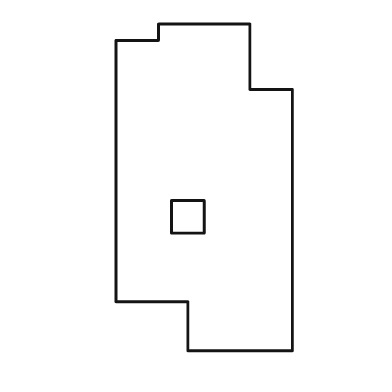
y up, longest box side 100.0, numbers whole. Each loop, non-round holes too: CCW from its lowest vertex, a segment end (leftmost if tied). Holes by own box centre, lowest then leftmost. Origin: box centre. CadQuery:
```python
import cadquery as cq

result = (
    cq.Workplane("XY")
    .moveTo(-5.0, -50.0)
    .lineTo(27.0, -50.0)
    .lineTo(27.0, 30.0)
    .lineTo(14.0, 30.0)
    .lineTo(14.0, 50.0)
    .lineTo(-14.0, 50.0)
    .lineTo(-14.0, 45.0)
    .lineTo(-27.0, 45.0)
    .lineTo(-27.0, -35.0)
    .lineTo(-5.0, -35.0)
    .close()
    .moveTo(-10.0, -14.0)
    .lineTo(0.0, -14.0)
    .lineTo(0.0, -4.0)
    .lineTo(-10.0, -4.0)
    .close()
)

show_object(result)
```